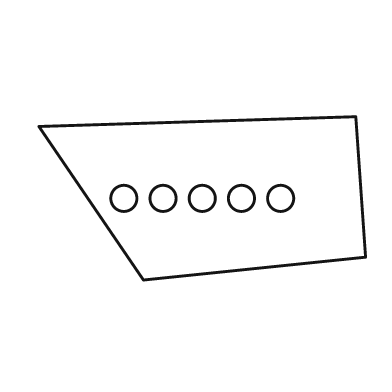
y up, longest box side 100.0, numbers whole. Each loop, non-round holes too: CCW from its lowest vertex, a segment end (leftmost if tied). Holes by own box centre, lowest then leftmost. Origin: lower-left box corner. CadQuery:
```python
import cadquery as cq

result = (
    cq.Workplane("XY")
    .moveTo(32.0, 0.0)
    .lineTo(100.0, 7.0)
    .lineTo(97.0, 50.0)
    .lineTo(0.0, 47.0)
    .close()
    .moveTo(26.0, 25.0)
    .circle(4.0)
    .moveTo(38.0, 25.0)
    .circle(4.0)
    .moveTo(50.0, 25.0)
    .circle(4.0)
    .moveTo(62.0, 25.0)
    .circle(4.0)
    .moveTo(74.0, 25.0)
    .circle(4.0)
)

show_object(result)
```